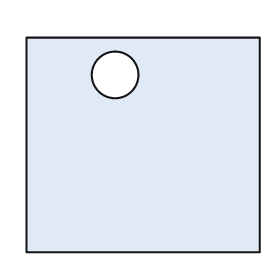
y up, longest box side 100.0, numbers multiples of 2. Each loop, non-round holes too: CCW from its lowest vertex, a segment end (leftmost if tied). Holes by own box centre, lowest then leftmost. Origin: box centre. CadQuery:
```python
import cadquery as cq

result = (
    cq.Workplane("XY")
    .moveTo(-50.0, -46.0)
    .lineTo(50.0, -46.0)
    .lineTo(50.0, 46.0)
    .lineTo(-50.0, 46.0)
    .close()
    .moveTo(-12.0, 30.0)
    .circle(10.0)
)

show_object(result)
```